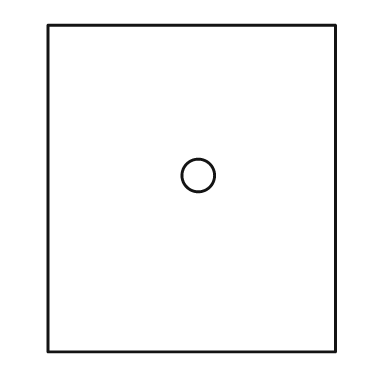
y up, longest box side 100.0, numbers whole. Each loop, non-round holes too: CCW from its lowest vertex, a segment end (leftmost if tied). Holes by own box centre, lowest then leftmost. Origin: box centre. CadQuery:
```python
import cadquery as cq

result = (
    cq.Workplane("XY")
    .moveTo(-44.0, -50.0)
    .lineTo(44.0, -50.0)
    .lineTo(44.0, 50.0)
    .lineTo(-44.0, 50.0)
    .close()
    .moveTo(2.0, 4.0)
    .circle(5.0)
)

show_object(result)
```